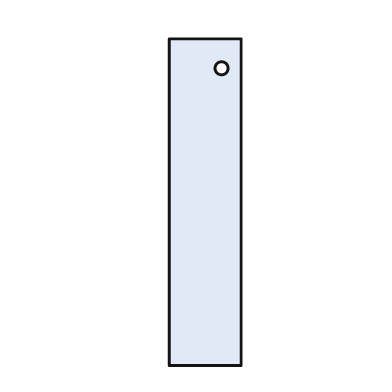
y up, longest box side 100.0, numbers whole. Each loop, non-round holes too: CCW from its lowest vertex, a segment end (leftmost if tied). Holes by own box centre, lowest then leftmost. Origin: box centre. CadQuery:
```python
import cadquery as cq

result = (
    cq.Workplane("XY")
    .moveTo(-11.0, -50.0)
    .lineTo(11.0, -50.0)
    .lineTo(11.0, 50.0)
    .lineTo(-11.0, 50.0)
    .close()
    .moveTo(5.0, 41.0)
    .circle(2.0)
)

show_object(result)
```